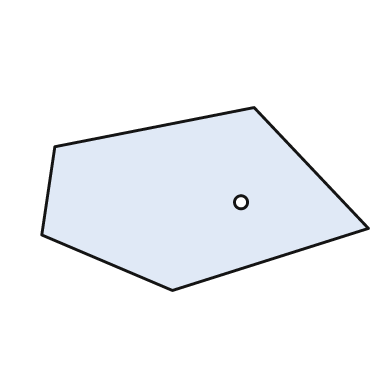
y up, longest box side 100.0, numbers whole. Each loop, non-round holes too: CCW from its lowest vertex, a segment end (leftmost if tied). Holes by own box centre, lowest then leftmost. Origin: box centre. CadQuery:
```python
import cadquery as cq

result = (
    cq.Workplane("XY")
    .moveTo(-10.0, -28.0)
    .lineTo(50.0, -9.0)
    .lineTo(15.0, 28.0)
    .lineTo(-46.0, 16.0)
    .lineTo(-50.0, -11.0)
    .close()
    .moveTo(11.0, -1.0)
    .circle(2.0)
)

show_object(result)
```